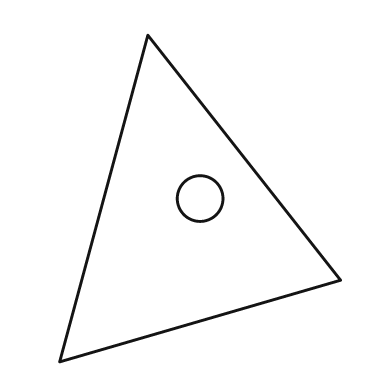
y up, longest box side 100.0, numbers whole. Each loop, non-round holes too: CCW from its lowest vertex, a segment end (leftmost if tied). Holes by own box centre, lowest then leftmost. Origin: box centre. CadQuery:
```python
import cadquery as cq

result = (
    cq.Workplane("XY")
    .moveTo(-43.0, -50.0)
    .lineTo(43.0, -25.0)
    .lineTo(-16.0, 50.0)
    .close()
    .moveTo(0.0, 0.0)
    .circle(7.0)
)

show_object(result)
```